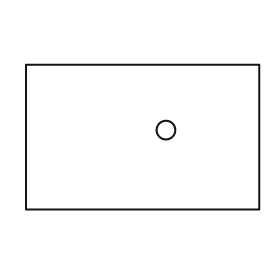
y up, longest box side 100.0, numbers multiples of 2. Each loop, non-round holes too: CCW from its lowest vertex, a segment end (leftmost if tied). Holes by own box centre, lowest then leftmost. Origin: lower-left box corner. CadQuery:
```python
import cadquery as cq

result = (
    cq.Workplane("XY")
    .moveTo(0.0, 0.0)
    .lineTo(100.0, 0.0)
    .lineTo(100.0, 62.0)
    .lineTo(0.0, 62.0)
    .close()
    .moveTo(60.0, 34.0)
    .circle(4.0)
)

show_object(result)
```